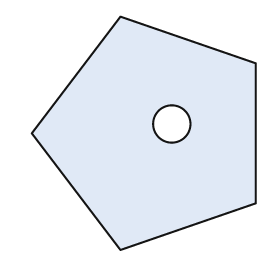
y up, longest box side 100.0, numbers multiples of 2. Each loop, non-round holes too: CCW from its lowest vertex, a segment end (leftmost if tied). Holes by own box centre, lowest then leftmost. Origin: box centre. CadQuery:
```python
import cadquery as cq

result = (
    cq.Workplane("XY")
    .moveTo(-10.0, -50.0)
    .lineTo(48.0, -30.0)
    .lineTo(48.0, 30.0)
    .lineTo(-10.0, 50.0)
    .lineTo(-48.0, 0.0)
    .close()
    .moveTo(12.0, 4.0)
    .circle(8.0)
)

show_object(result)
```